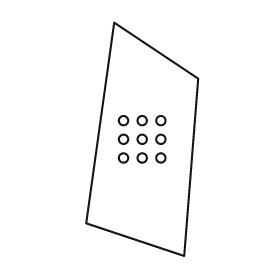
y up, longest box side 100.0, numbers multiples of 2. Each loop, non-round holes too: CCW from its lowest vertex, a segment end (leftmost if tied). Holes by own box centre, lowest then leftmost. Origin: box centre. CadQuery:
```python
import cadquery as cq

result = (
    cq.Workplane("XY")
    .moveTo(18.0, -50.0)
    .lineTo(24.0, 26.0)
    .lineTo(-12.0, 50.0)
    .lineTo(-24.0, -36.0)
    .close()
    .moveTo(-8.0, -8.0)
    .circle(2.0)
    .moveTo(0.0, -8.0)
    .circle(2.0)
    .moveTo(8.0, -8.0)
    .circle(2.0)
    .moveTo(-8.0, 0.0)
    .circle(2.0)
    .moveTo(0.0, 0.0)
    .circle(2.0)
    .moveTo(8.0, 0.0)
    .circle(2.0)
    .moveTo(-8.0, 8.0)
    .circle(2.0)
    .moveTo(0.0, 8.0)
    .circle(2.0)
    .moveTo(8.0, 8.0)
    .circle(2.0)
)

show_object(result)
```